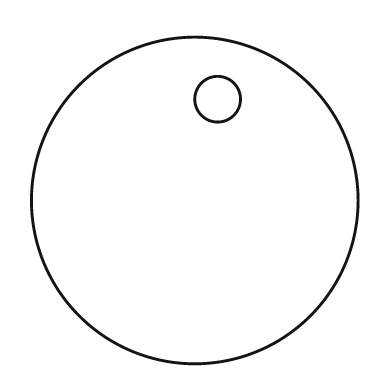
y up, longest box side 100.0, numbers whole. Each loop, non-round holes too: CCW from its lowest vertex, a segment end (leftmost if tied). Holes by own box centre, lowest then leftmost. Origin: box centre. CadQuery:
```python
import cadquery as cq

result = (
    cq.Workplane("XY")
    .moveTo(0.0, 0.0)
    .circle(50.0)
    .moveTo(7.0, 31.0)
    .circle(7.0)
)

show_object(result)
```